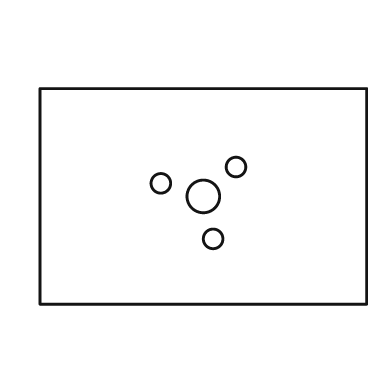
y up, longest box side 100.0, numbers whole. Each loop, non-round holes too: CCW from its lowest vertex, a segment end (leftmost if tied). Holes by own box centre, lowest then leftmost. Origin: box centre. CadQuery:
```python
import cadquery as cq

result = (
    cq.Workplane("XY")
    .moveTo(-50.0, -33.0)
    .lineTo(50.0, -33.0)
    .lineTo(50.0, 33.0)
    .lineTo(-50.0, 33.0)
    .close()
    .moveTo(3.0, -13.0)
    .circle(3.0)
    .moveTo(0.0, 0.0)
    .circle(5.0)
    .moveTo(-13.0, 4.0)
    .circle(3.0)
    .moveTo(10.0, 9.0)
    .circle(3.0)
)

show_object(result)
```